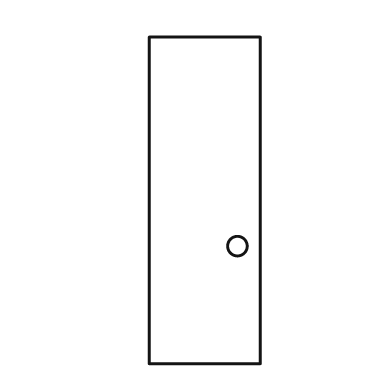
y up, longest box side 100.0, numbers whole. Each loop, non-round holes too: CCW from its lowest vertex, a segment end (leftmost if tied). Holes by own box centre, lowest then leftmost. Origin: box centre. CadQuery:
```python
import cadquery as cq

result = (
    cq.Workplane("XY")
    .moveTo(-17.0, -50.0)
    .lineTo(17.0, -50.0)
    .lineTo(17.0, 50.0)
    .lineTo(-17.0, 50.0)
    .close()
    .moveTo(10.0, -14.0)
    .circle(3.0)
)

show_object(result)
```